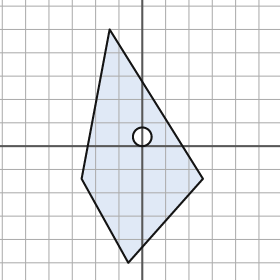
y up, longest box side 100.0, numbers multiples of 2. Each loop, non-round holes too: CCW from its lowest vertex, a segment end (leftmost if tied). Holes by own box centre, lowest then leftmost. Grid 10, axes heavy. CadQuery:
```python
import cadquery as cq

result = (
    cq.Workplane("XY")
    .moveTo(-6.0, -50.0)
    .lineTo(26.0, -14.0)
    .lineTo(-14.0, 50.0)
    .lineTo(-26.0, -14.0)
    .close()
    .moveTo(0.0, 4.0)
    .circle(4.0)
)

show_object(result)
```